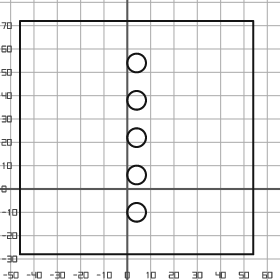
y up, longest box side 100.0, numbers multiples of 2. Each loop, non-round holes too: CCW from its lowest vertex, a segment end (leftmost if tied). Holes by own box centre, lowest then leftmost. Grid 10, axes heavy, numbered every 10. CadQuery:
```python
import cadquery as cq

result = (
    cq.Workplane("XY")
    .moveTo(-46.0, -28.0)
    .lineTo(54.0, -28.0)
    .lineTo(54.0, 72.0)
    .lineTo(-46.0, 72.0)
    .close()
    .moveTo(4.0, -10.0)
    .circle(4.0)
    .moveTo(4.0, 6.0)
    .circle(4.0)
    .moveTo(4.0, 22.0)
    .circle(4.0)
    .moveTo(4.0, 38.0)
    .circle(4.0)
    .moveTo(4.0, 54.0)
    .circle(4.0)
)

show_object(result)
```